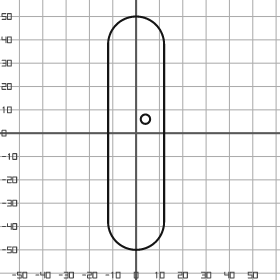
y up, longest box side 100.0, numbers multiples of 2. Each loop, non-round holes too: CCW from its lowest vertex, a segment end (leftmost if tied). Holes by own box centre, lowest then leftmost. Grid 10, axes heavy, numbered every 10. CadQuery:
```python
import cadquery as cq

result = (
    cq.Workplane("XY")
    .moveTo(-12.0, -38.0)
    .threePointArc((0.0, -50.0), (12.0, -38.0))
    .lineTo(12.0, 38.0)
    .threePointArc((0.0, 50.0), (-12.0, 38.0))
    .close()
    .moveTo(4.0, 6.0)
    .circle(2.0)
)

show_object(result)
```